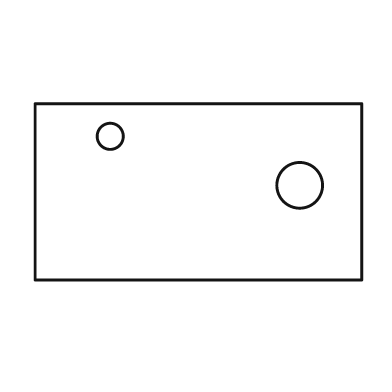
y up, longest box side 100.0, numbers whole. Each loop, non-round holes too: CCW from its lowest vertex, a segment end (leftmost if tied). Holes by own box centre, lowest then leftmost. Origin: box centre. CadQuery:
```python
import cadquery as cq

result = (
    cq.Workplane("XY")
    .moveTo(-50.0, -27.0)
    .lineTo(50.0, -27.0)
    .lineTo(50.0, 27.0)
    .lineTo(-50.0, 27.0)
    .close()
    .moveTo(31.0, 2.0)
    .circle(7.0)
    .moveTo(-27.0, 17.0)
    .circle(4.0)
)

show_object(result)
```